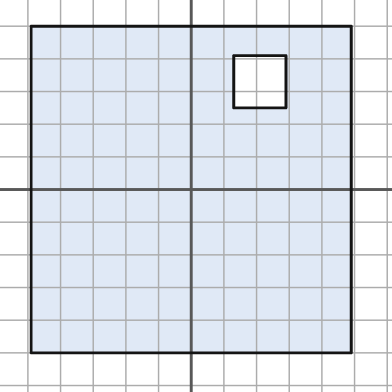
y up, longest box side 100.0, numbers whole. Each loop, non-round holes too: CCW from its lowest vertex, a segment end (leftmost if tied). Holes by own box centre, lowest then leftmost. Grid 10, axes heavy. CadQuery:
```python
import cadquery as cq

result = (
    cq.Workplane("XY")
    .moveTo(-49.0, -50.0)
    .lineTo(49.0, -50.0)
    .lineTo(49.0, 50.0)
    .lineTo(-49.0, 50.0)
    .close()
    .moveTo(13.0, 25.0)
    .lineTo(29.0, 25.0)
    .lineTo(29.0, 41.0)
    .lineTo(13.0, 41.0)
    .close()
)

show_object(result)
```